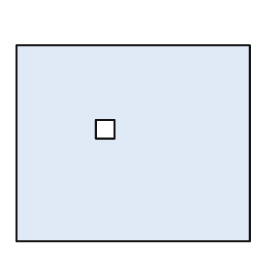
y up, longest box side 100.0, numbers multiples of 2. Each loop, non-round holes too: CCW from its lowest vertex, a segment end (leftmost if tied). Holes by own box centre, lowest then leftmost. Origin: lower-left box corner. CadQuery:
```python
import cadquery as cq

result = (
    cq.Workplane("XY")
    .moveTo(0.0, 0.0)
    .lineTo(100.0, 0.0)
    .lineTo(100.0, 84.0)
    .lineTo(0.0, 84.0)
    .close()
    .moveTo(34.0, 44.0)
    .lineTo(42.0, 44.0)
    .lineTo(42.0, 52.0)
    .lineTo(34.0, 52.0)
    .close()
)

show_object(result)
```